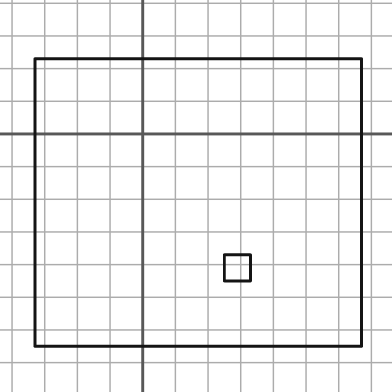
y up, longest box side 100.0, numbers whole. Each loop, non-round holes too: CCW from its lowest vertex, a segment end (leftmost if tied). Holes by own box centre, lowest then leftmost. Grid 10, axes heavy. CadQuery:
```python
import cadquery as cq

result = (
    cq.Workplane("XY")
    .moveTo(-33.0, -65.0)
    .lineTo(67.0, -65.0)
    .lineTo(67.0, 23.0)
    .lineTo(-33.0, 23.0)
    .close()
    .moveTo(25.0, -45.0)
    .lineTo(33.0, -45.0)
    .lineTo(33.0, -37.0)
    .lineTo(25.0, -37.0)
    .close()
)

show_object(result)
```